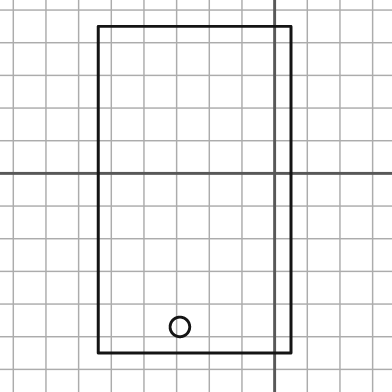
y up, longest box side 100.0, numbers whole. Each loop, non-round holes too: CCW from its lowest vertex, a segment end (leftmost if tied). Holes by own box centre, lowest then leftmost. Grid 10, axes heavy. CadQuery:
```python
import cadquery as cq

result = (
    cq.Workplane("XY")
    .moveTo(-54.0, -55.0)
    .lineTo(5.0, -55.0)
    .lineTo(5.0, 45.0)
    .lineTo(-54.0, 45.0)
    .close()
    .moveTo(-29.0, -47.0)
    .circle(3.0)
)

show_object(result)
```